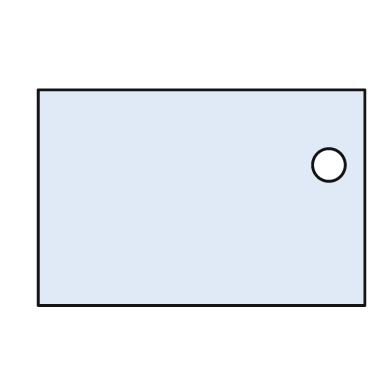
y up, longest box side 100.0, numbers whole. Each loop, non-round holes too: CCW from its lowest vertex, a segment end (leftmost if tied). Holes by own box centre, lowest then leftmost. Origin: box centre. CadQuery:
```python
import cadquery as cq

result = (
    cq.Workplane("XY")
    .moveTo(-50.0, -33.0)
    .lineTo(50.0, -33.0)
    .lineTo(50.0, 33.0)
    .lineTo(-50.0, 33.0)
    .close()
    .moveTo(39.0, 10.0)
    .circle(5.0)
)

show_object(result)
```